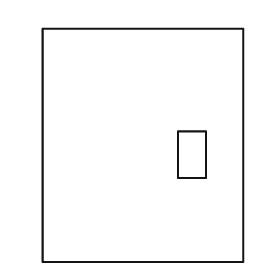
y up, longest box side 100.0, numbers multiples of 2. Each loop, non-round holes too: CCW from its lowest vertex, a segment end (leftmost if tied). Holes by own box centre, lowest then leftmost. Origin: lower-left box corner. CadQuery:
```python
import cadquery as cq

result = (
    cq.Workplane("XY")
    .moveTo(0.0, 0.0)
    .lineTo(86.0, 0.0)
    .lineTo(86.0, 100.0)
    .lineTo(0.0, 100.0)
    .close()
    .moveTo(58.0, 36.0)
    .lineTo(70.0, 36.0)
    .lineTo(70.0, 56.0)
    .lineTo(58.0, 56.0)
    .close()
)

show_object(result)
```